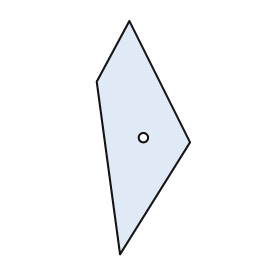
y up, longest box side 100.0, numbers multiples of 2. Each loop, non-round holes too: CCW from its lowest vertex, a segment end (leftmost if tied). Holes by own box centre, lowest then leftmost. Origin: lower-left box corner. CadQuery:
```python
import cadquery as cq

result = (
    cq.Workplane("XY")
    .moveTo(10.0, 0.0)
    .lineTo(40.0, 48.0)
    .lineTo(14.0, 100.0)
    .lineTo(0.0, 74.0)
    .close()
    .moveTo(20.0, 50.0)
    .circle(2.0)
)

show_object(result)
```